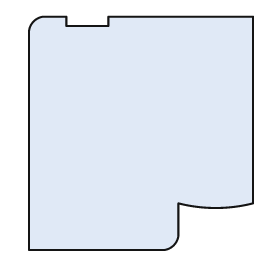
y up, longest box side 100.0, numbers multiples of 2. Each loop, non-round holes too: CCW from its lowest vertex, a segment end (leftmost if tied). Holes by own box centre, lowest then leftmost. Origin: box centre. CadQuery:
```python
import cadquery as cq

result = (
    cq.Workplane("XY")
    .moveTo(-48.0, -50.0)
    .lineTo(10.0, -50.0)
    .threePointArc((14.0, -48.0), (16.0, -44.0))
    .lineTo(16.0, -30.0)
    .threePointArc((32.0, -32.0), (48.0, -30.0))
    .lineTo(48.0, 50.0)
    .lineTo(-14.0, 50.0)
    .lineTo(-14.0, 46.0)
    .lineTo(-32.0, 46.0)
    .lineTo(-32.0, 50.0)
    .lineTo(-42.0, 50.0)
    .threePointArc((-46.0, 48.0), (-48.0, 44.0))
    .close()
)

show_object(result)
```